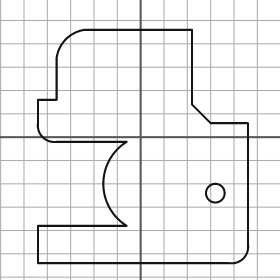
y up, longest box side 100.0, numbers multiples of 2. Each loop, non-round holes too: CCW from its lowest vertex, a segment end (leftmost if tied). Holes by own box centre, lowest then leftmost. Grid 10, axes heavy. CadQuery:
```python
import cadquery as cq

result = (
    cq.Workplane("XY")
    .moveTo(-44.0, -54.0)
    .lineTo(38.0, -54.0)
    .threePointArc((44.0, -52.0), (46.0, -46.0))
    .lineTo(46.0, 6.0)
    .lineTo(30.0, 6.0)
    .lineTo(22.0, 14.0)
    .lineTo(22.0, 46.0)
    .lineTo(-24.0, 46.0)
    .threePointArc((-32.0, 42.0), (-36.0, 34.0))
    .lineTo(-36.0, 16.0)
    .lineTo(-44.0, 16.0)
    .lineTo(-44.0, 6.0)
    .threePointArc((-42.0, 0.0), (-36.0, -2.0))
    .lineTo(-6.0, -2.0)
    .threePointArc((-16.0, -20.0), (-6.0, -38.0))
    .lineTo(-44.0, -38.0)
    .close()
    .moveTo(32.0, -24.0)
    .circle(4.0)
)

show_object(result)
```